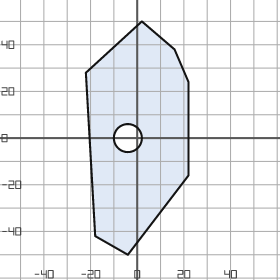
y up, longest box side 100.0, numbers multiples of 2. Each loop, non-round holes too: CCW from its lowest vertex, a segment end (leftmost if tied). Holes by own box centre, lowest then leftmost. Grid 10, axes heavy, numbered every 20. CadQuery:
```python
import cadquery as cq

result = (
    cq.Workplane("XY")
    .moveTo(-4.0, -50.0)
    .lineTo(22.0, -16.0)
    .lineTo(22.0, 24.0)
    .lineTo(16.0, 38.0)
    .lineTo(2.0, 50.0)
    .lineTo(-22.0, 28.0)
    .lineTo(-18.0, -42.0)
    .close()
    .moveTo(-4.0, 0.0)
    .circle(6.0)
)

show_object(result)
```